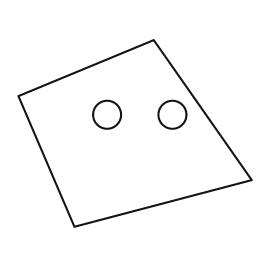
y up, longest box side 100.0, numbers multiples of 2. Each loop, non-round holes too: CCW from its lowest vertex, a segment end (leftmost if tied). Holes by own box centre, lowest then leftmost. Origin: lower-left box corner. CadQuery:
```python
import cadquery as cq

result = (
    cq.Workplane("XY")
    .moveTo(24.0, 0.0)
    .lineTo(100.0, 20.0)
    .lineTo(58.0, 80.0)
    .lineTo(0.0, 56.0)
    .close()
    .moveTo(38.0, 48.0)
    .circle(6.0)
    .moveTo(66.0, 48.0)
    .circle(6.0)
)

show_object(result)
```